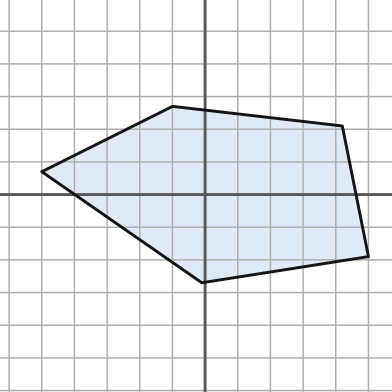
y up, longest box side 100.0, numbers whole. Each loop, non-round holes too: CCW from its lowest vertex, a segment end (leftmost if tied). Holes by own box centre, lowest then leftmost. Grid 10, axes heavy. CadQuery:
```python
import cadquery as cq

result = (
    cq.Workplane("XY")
    .moveTo(-1.0, -27.0)
    .lineTo(50.0, -19.0)
    .lineTo(42.0, 21.0)
    .lineTo(-10.0, 27.0)
    .lineTo(-50.0, 7.0)
    .close()
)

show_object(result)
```